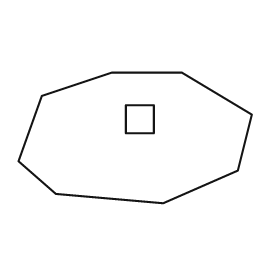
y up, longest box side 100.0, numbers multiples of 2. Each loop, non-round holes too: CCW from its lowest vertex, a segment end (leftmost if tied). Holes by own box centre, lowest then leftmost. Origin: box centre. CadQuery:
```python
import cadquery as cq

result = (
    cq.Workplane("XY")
    .moveTo(12.0, -28.0)
    .lineTo(44.0, -14.0)
    .lineTo(50.0, 10.0)
    .lineTo(20.0, 28.0)
    .lineTo(-10.0, 28.0)
    .lineTo(-40.0, 18.0)
    .lineTo(-50.0, -10.0)
    .lineTo(-34.0, -24.0)
    .close()
    .moveTo(-4.0, 2.0)
    .lineTo(8.0, 2.0)
    .lineTo(8.0, 14.0)
    .lineTo(-4.0, 14.0)
    .close()
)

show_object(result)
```